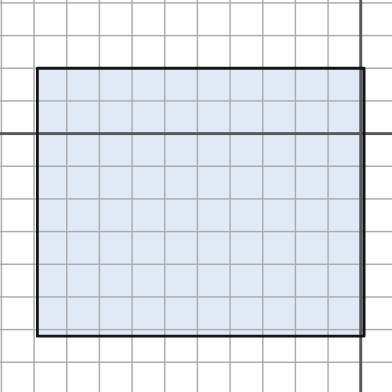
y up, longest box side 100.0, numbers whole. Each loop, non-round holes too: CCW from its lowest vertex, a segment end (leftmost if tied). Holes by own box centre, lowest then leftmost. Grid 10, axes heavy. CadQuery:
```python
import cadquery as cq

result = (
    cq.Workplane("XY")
    .moveTo(-99.0, -62.0)
    .lineTo(1.0, -62.0)
    .lineTo(1.0, 20.0)
    .lineTo(-99.0, 20.0)
    .close()
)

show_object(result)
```